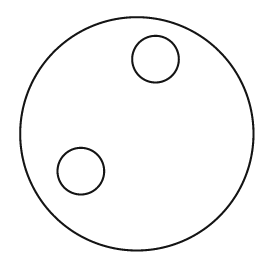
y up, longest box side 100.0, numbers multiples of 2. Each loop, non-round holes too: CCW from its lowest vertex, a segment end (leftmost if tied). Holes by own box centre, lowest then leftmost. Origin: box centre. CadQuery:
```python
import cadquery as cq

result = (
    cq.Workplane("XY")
    .moveTo(0.0, 0.0)
    .circle(50.0)
    .moveTo(-24.0, -16.0)
    .circle(10.0)
    .moveTo(8.0, 32.0)
    .circle(10.0)
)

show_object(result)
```